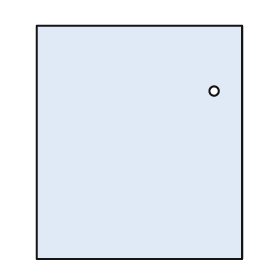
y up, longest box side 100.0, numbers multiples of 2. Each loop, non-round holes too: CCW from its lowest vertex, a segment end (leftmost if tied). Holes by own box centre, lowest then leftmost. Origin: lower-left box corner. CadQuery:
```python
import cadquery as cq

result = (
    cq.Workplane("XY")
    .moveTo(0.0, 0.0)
    .lineTo(88.0, 0.0)
    .lineTo(88.0, 100.0)
    .lineTo(0.0, 100.0)
    .close()
    .moveTo(76.0, 72.0)
    .circle(2.0)
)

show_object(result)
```